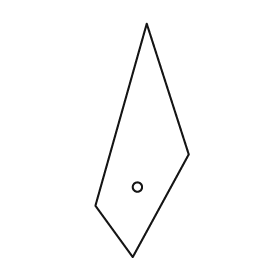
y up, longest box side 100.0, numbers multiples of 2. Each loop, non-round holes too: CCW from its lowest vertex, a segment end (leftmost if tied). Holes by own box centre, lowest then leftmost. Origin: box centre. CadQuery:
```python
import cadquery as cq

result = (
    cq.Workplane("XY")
    .moveTo(-4.0, -50.0)
    .lineTo(20.0, -6.0)
    .lineTo(2.0, 50.0)
    .lineTo(-20.0, -28.0)
    .close()
    .moveTo(-2.0, -20.0)
    .circle(2.0)
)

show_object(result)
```